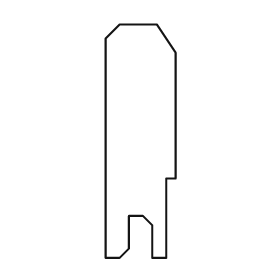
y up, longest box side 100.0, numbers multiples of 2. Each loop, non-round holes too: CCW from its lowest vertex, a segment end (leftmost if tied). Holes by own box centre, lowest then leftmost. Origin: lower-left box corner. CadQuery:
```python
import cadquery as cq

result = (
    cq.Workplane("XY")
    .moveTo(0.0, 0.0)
    .lineTo(6.0, 0.0)
    .lineTo(10.0, 4.0)
    .lineTo(10.0, 18.0)
    .lineTo(16.0, 18.0)
    .lineTo(20.0, 14.0)
    .lineTo(20.0, 0.0)
    .lineTo(26.0, 0.0)
    .lineTo(26.0, 34.0)
    .lineTo(30.0, 34.0)
    .lineTo(30.0, 88.0)
    .lineTo(22.0, 100.0)
    .lineTo(6.0, 100.0)
    .lineTo(0.0, 94.0)
    .close()
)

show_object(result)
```